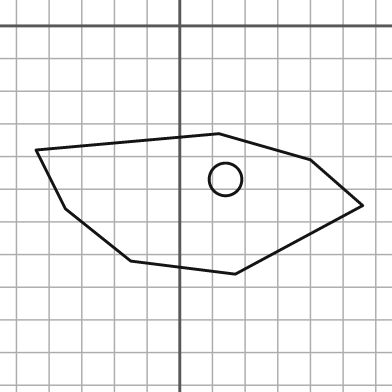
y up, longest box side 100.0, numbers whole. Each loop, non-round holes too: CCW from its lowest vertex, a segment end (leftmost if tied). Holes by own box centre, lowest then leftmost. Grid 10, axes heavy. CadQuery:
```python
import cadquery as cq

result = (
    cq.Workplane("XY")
    .moveTo(17.0, -76.0)
    .lineTo(56.0, -55.0)
    .lineTo(40.0, -41.0)
    .lineTo(12.0, -33.0)
    .lineTo(-44.0, -38.0)
    .lineTo(-35.0, -56.0)
    .lineTo(-15.0, -72.0)
    .close()
    .moveTo(14.0, -47.0)
    .circle(5.0)
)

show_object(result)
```